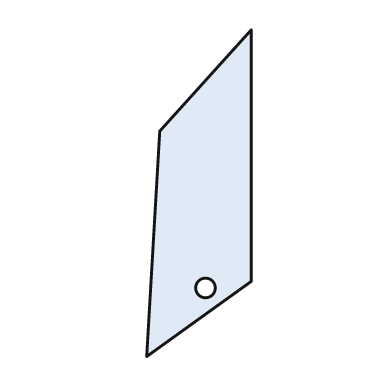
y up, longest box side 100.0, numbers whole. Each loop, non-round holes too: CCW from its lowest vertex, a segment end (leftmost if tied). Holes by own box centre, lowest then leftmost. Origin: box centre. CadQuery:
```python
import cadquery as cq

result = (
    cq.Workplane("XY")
    .moveTo(-16.0, -50.0)
    .lineTo(16.0, -27.0)
    .lineTo(16.0, 50.0)
    .lineTo(-12.0, 19.0)
    .close()
    .moveTo(2.0, -29.0)
    .circle(3.0)
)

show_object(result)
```